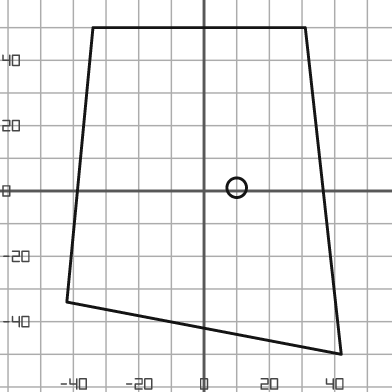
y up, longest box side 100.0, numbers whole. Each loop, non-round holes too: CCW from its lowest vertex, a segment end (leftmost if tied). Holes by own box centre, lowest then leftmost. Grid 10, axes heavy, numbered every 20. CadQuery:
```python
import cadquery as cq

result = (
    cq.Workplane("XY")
    .moveTo(42.0, -50.0)
    .lineTo(31.0, 50.0)
    .lineTo(-34.0, 50.0)
    .lineTo(-42.0, -34.0)
    .close()
    .moveTo(10.0, 1.0)
    .circle(3.0)
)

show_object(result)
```